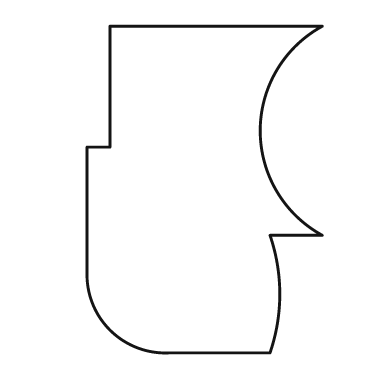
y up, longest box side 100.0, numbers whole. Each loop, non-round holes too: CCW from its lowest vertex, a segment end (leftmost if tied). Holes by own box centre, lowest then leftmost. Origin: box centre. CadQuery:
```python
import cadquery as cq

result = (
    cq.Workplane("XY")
    .moveTo(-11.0, -50.0)
    .lineTo(20.0, -50.0)
    .threePointArc((23.0, -32.0), (20.0, -14.0))
    .lineTo(36.0, -14.0)
    .threePointArc((17.0, 18.0), (36.0, 50.0))
    .lineTo(-29.0, 50.0)
    .lineTo(-29.0, 13.0)
    .lineTo(-36.0, 13.0)
    .lineTo(-36.0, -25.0)
    .threePointArc((-29.0, -43.0), (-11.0, -50.0))
    .close()
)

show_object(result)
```